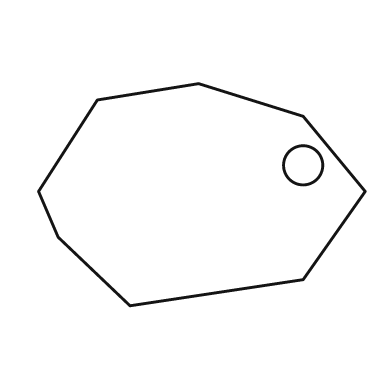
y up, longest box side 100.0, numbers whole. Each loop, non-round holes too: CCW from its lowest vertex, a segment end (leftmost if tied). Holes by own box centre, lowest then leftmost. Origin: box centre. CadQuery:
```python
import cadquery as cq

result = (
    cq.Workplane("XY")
    .moveTo(-22.0, -34.0)
    .lineTo(31.0, -26.0)
    .lineTo(50.0, 1.0)
    .lineTo(31.0, 24.0)
    .lineTo(-1.0, 34.0)
    .lineTo(-32.0, 29.0)
    .lineTo(-50.0, 1.0)
    .lineTo(-44.0, -13.0)
    .close()
    .moveTo(31.0, 9.0)
    .circle(6.0)
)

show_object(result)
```